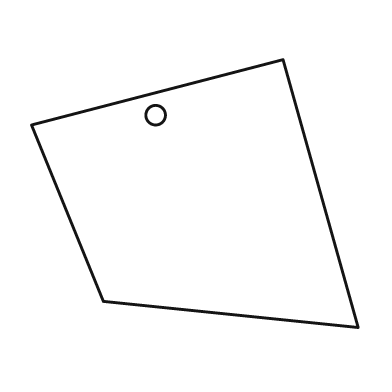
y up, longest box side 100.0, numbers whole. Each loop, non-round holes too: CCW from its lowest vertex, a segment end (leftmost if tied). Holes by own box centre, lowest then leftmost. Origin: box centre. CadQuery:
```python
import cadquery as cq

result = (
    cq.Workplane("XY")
    .moveTo(50.0, -41.0)
    .lineTo(27.0, 41.0)
    .lineTo(-50.0, 21.0)
    .lineTo(-28.0, -33.0)
    .close()
    .moveTo(-12.0, 24.0)
    .circle(3.0)
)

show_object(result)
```